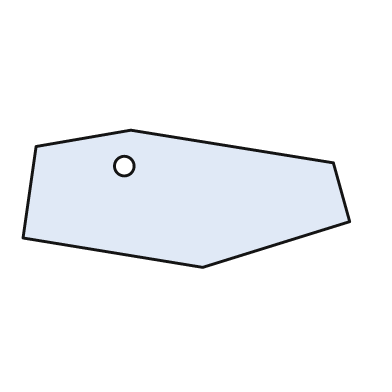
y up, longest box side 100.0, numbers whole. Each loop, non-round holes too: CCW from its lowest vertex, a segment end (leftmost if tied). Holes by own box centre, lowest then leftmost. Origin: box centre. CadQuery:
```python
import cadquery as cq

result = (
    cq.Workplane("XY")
    .moveTo(5.0, -21.0)
    .lineTo(50.0, -7.0)
    .lineTo(45.0, 11.0)
    .lineTo(-17.0, 21.0)
    .lineTo(-46.0, 16.0)
    .lineTo(-50.0, -12.0)
    .close()
    .moveTo(-19.0, 10.0)
    .circle(3.0)
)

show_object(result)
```